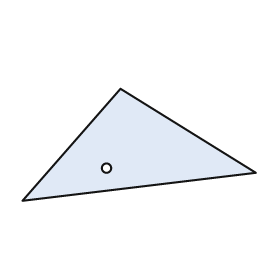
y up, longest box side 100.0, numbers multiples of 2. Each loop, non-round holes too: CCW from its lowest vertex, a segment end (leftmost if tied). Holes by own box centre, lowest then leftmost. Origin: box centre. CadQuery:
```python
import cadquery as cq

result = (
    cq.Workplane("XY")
    .moveTo(-50.0, -24.0)
    .lineTo(50.0, -12.0)
    .lineTo(-8.0, 24.0)
    .close()
    .moveTo(-14.0, -10.0)
    .circle(2.0)
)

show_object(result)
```